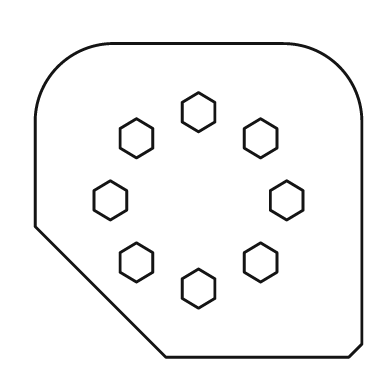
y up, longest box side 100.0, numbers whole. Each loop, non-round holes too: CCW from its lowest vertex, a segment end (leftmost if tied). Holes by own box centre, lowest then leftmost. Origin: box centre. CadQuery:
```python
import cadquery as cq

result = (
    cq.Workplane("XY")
    .moveTo(-10.0, -48.0)
    .lineTo(46.0, -48.0)
    .lineTo(50.0, -44.0)
    .lineTo(50.0, 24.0)
    .threePointArc((43.0, 41.0), (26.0, 48.0))
    .lineTo(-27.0, 48.0)
    .threePointArc((-43.0, 41.0), (-50.0, 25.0))
    .lineTo(-50.0, -8.0)
    .close()
    .moveTo(0.0, -33.0)
    .lineTo(5.0, -30.0)
    .lineTo(5.0, -24.0)
    .lineTo(0.0, -21.0)
    .lineTo(-5.0, -24.0)
    .lineTo(-5.0, -30.0)
    .close()
    .moveTo(-19.0, -25.0)
    .lineTo(-14.0, -22.0)
    .lineTo(-14.0, -16.0)
    .lineTo(-19.0, -13.0)
    .lineTo(-24.0, -16.0)
    .lineTo(-24.0, -22.0)
    .close()
    .moveTo(19.0, -25.0)
    .lineTo(24.0, -22.0)
    .lineTo(24.0, -16.0)
    .lineTo(19.0, -13.0)
    .lineTo(14.0, -16.0)
    .lineTo(14.0, -22.0)
    .close()
    .moveTo(-27.0, -6.0)
    .lineTo(-22.0, -3.0)
    .lineTo(-22.0, 3.0)
    .lineTo(-27.0, 6.0)
    .lineTo(-32.0, 3.0)
    .lineTo(-32.0, -3.0)
    .close()
    .moveTo(27.0, -6.0)
    .lineTo(32.0, -3.0)
    .lineTo(32.0, 3.0)
    .lineTo(27.0, 6.0)
    .lineTo(22.0, 3.0)
    .lineTo(22.0, -3.0)
    .close()
    .moveTo(-19.0, 13.0)
    .lineTo(-14.0, 16.0)
    .lineTo(-14.0, 22.0)
    .lineTo(-19.0, 25.0)
    .lineTo(-24.0, 22.0)
    .lineTo(-24.0, 16.0)
    .close()
    .moveTo(19.0, 13.0)
    .lineTo(24.0, 16.0)
    .lineTo(24.0, 22.0)
    .lineTo(19.0, 25.0)
    .lineTo(14.0, 22.0)
    .lineTo(14.0, 16.0)
    .close()
    .moveTo(0.0, 21.0)
    .lineTo(5.0, 24.0)
    .lineTo(5.0, 30.0)
    .lineTo(0.0, 33.0)
    .lineTo(-5.0, 30.0)
    .lineTo(-5.0, 24.0)
    .close()
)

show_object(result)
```